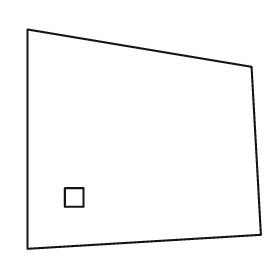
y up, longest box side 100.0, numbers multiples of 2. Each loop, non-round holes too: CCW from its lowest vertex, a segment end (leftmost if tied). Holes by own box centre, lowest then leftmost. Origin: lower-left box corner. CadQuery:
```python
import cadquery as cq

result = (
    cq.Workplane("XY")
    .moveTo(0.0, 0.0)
    .lineTo(100.0, 6.0)
    .lineTo(96.0, 78.0)
    .lineTo(0.0, 94.0)
    .close()
    .moveTo(16.0, 18.0)
    .lineTo(24.0, 18.0)
    .lineTo(24.0, 26.0)
    .lineTo(16.0, 26.0)
    .close()
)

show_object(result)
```